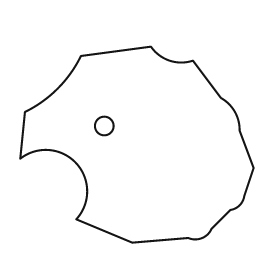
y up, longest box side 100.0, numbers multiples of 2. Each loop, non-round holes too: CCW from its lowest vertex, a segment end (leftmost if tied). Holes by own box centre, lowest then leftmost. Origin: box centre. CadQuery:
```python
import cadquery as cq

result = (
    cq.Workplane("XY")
    .moveTo(-2.0, -42.0)
    .lineTo(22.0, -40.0)
    .threePointArc((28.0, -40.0), (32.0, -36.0))
    .lineTo(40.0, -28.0)
    .threePointArc((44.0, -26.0), (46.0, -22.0))
    .lineTo(50.0, -10.0)
    .lineTo(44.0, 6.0)
    .threePointArc((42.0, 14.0), (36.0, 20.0))
    .lineTo(24.0, 36.0)
    .threePointArc((14.0, 36.0), (6.0, 42.0))
    .lineTo(-24.0, 38.0)
    .threePointArc((-34.0, 24.0), (-48.0, 14.0))
    .lineTo(-50.0, -6.0)
    .threePointArc((-26.0, -8.0), (-26.0, -32.0))
    .close()
    .moveTo(-14.0, 8.0)
    .circle(4.0)
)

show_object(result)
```